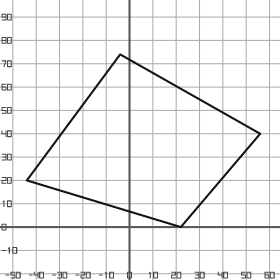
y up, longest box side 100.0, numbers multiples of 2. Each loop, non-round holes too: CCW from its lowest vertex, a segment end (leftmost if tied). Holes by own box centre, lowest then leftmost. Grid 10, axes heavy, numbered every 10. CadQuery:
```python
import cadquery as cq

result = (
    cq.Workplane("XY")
    .moveTo(22.0, 0.0)
    .lineTo(56.0, 40.0)
    .lineTo(-4.0, 74.0)
    .lineTo(-44.0, 20.0)
    .close()
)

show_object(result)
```